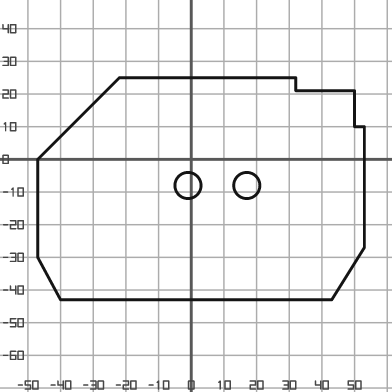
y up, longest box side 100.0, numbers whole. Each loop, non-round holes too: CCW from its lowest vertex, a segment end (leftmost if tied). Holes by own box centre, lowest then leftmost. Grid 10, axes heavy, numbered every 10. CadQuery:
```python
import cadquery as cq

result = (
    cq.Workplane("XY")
    .moveTo(-40.0, -43.0)
    .lineTo(43.0, -43.0)
    .lineTo(53.0, -27.0)
    .lineTo(53.0, 10.0)
    .lineTo(50.0, 10.0)
    .lineTo(50.0, 21.0)
    .lineTo(32.0, 21.0)
    .lineTo(32.0, 25.0)
    .lineTo(-22.0, 25.0)
    .lineTo(-47.0, 0.0)
    .lineTo(-47.0, -30.0)
    .close()
    .moveTo(-1.0, -8.0)
    .circle(4.0)
    .moveTo(17.0, -8.0)
    .circle(4.0)
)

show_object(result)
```